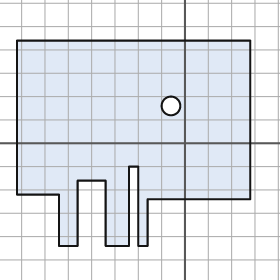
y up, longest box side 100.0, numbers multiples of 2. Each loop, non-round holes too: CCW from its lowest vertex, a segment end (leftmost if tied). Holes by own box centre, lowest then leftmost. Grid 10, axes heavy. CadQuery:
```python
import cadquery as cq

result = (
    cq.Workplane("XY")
    .moveTo(-54.0, -44.0)
    .lineTo(-46.0, -44.0)
    .lineTo(-46.0, -16.0)
    .lineTo(-34.0, -16.0)
    .lineTo(-34.0, -44.0)
    .lineTo(-24.0, -44.0)
    .lineTo(-24.0, -10.0)
    .lineTo(-20.0, -10.0)
    .lineTo(-20.0, -44.0)
    .lineTo(-16.0, -44.0)
    .lineTo(-16.0, -24.0)
    .lineTo(28.0, -24.0)
    .lineTo(28.0, 44.0)
    .lineTo(-72.0, 44.0)
    .lineTo(-72.0, -22.0)
    .lineTo(-54.0, -22.0)
    .close()
    .moveTo(-6.0, 16.0)
    .circle(4.0)
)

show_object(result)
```